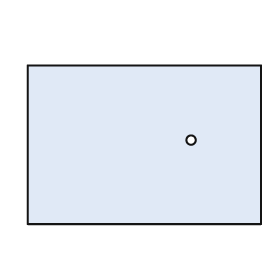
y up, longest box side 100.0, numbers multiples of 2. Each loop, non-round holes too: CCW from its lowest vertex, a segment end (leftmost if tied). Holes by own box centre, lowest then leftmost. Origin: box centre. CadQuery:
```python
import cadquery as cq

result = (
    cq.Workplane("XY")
    .moveTo(-50.0, -34.0)
    .lineTo(50.0, -34.0)
    .lineTo(50.0, 34.0)
    .lineTo(-50.0, 34.0)
    .close()
    .moveTo(20.0, 2.0)
    .circle(2.0)
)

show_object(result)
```